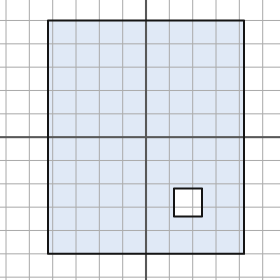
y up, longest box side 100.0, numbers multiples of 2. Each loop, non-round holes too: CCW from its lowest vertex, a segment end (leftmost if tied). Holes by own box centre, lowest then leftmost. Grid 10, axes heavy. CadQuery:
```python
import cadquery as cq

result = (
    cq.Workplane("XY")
    .moveTo(-42.0, -50.0)
    .lineTo(42.0, -50.0)
    .lineTo(42.0, 50.0)
    .lineTo(-42.0, 50.0)
    .close()
    .moveTo(12.0, -34.0)
    .lineTo(24.0, -34.0)
    .lineTo(24.0, -22.0)
    .lineTo(12.0, -22.0)
    .close()
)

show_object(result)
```